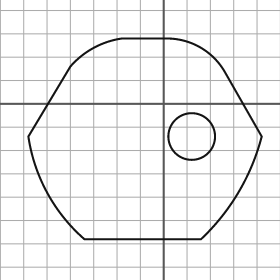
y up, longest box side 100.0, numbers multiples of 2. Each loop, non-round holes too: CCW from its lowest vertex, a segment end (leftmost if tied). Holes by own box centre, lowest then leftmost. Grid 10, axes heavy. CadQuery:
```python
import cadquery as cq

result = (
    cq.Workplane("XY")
    .moveTo(-34.0, -58.0)
    .lineTo(16.0, -58.0)
    .threePointArc((32.0, -38.0), (42.0, -14.0))
    .lineTo(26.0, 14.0)
    .threePointArc((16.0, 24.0), (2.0, 28.0))
    .lineTo(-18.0, 28.0)
    .threePointArc((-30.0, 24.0), (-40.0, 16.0))
    .lineTo(-58.0, -14.0)
    .threePointArc((-50.0, -38.0), (-34.0, -58.0))
    .close()
    .moveTo(12.0, -14.0)
    .circle(10.0)
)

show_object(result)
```